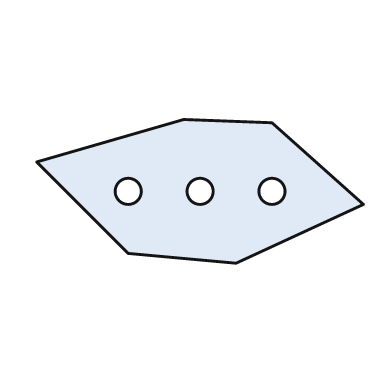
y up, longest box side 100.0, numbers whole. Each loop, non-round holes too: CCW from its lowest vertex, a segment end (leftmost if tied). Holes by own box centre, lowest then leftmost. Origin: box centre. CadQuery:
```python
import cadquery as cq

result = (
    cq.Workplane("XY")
    .moveTo(11.0, -22.0)
    .lineTo(50.0, -4.0)
    .lineTo(22.0, 21.0)
    .lineTo(-5.0, 22.0)
    .lineTo(-50.0, 9.0)
    .lineTo(-22.0, -19.0)
    .close()
    .moveTo(-22.0, 0.0)
    .circle(4.0)
    .moveTo(0.0, 0.0)
    .circle(4.0)
    .moveTo(22.0, 0.0)
    .circle(4.0)
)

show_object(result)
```